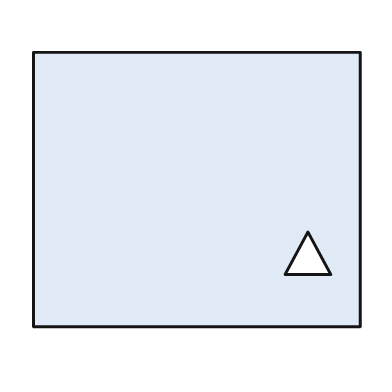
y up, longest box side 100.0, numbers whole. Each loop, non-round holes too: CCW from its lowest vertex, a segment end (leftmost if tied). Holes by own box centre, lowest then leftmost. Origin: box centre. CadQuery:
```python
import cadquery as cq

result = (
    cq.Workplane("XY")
    .moveTo(-50.0, -42.0)
    .lineTo(50.0, -42.0)
    .lineTo(50.0, 42.0)
    .lineTo(-50.0, 42.0)
    .close()
    .moveTo(27.0, -26.0)
    .lineTo(41.0, -26.0)
    .lineTo(34.0, -13.0)
    .close()
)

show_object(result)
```